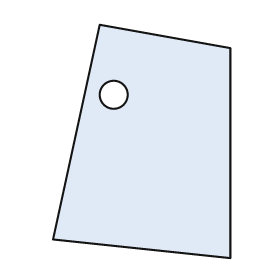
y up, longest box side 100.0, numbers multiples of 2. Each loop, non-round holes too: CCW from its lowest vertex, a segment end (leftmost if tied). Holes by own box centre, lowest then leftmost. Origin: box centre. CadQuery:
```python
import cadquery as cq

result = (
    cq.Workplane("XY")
    .moveTo(38.0, -50.0)
    .lineTo(38.0, 40.0)
    .lineTo(-18.0, 50.0)
    .lineTo(-38.0, -42.0)
    .close()
    .moveTo(-12.0, 20.0)
    .circle(6.0)
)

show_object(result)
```